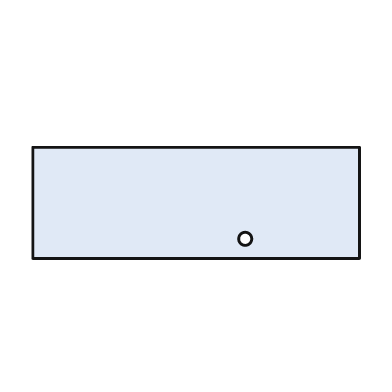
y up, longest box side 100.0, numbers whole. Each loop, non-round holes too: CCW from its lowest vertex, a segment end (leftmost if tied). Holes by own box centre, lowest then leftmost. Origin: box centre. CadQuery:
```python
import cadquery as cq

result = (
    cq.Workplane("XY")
    .moveTo(-50.0, -17.0)
    .lineTo(50.0, -17.0)
    .lineTo(50.0, 17.0)
    .lineTo(-50.0, 17.0)
    .close()
    .moveTo(15.0, -11.0)
    .circle(2.0)
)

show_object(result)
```